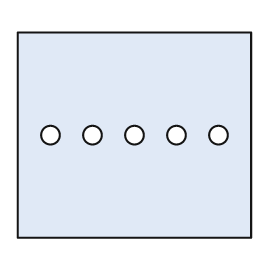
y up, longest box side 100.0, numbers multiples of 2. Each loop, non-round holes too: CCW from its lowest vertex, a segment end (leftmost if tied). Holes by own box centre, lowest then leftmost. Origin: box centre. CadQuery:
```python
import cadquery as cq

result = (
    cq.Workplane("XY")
    .moveTo(-50.0, -44.0)
    .lineTo(50.0, -44.0)
    .lineTo(50.0, 44.0)
    .lineTo(-50.0, 44.0)
    .close()
    .moveTo(-36.0, 0.0)
    .circle(4.0)
    .moveTo(-18.0, 0.0)
    .circle(4.0)
    .moveTo(0.0, 0.0)
    .circle(4.0)
    .moveTo(18.0, 0.0)
    .circle(4.0)
    .moveTo(36.0, 0.0)
    .circle(4.0)
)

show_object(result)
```